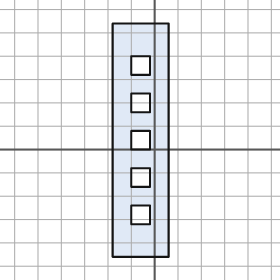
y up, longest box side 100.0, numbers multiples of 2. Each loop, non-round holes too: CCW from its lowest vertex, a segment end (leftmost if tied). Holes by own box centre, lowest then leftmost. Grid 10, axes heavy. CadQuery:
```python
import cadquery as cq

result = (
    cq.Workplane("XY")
    .moveTo(-18.0, -46.0)
    .lineTo(6.0, -46.0)
    .lineTo(6.0, 54.0)
    .lineTo(-18.0, 54.0)
    .close()
    .moveTo(-10.0, -32.0)
    .lineTo(-2.0, -32.0)
    .lineTo(-2.0, -24.0)
    .lineTo(-10.0, -24.0)
    .close()
    .moveTo(-10.0, -16.0)
    .lineTo(-2.0, -16.0)
    .lineTo(-2.0, -8.0)
    .lineTo(-10.0, -8.0)
    .close()
    .moveTo(-10.0, 0.0)
    .lineTo(-2.0, 0.0)
    .lineTo(-2.0, 8.0)
    .lineTo(-10.0, 8.0)
    .close()
    .moveTo(-10.0, 16.0)
    .lineTo(-2.0, 16.0)
    .lineTo(-2.0, 24.0)
    .lineTo(-10.0, 24.0)
    .close()
    .moveTo(-10.0, 32.0)
    .lineTo(-2.0, 32.0)
    .lineTo(-2.0, 40.0)
    .lineTo(-10.0, 40.0)
    .close()
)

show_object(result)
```